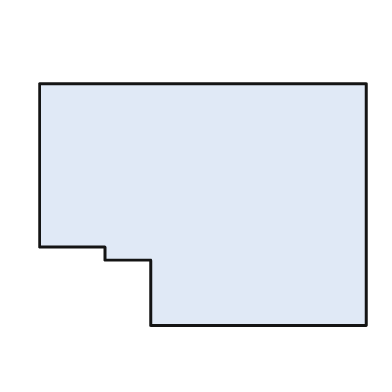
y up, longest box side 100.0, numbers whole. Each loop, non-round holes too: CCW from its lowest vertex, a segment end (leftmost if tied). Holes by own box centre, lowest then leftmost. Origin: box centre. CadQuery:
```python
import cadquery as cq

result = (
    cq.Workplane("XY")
    .moveTo(-16.0, -37.0)
    .lineTo(50.0, -37.0)
    .lineTo(50.0, 37.0)
    .lineTo(-50.0, 37.0)
    .lineTo(-50.0, -13.0)
    .lineTo(-30.0, -13.0)
    .lineTo(-30.0, -17.0)
    .lineTo(-16.0, -17.0)
    .close()
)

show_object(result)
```